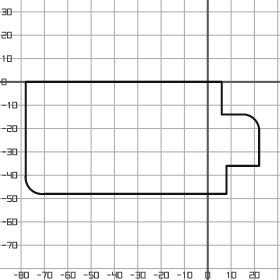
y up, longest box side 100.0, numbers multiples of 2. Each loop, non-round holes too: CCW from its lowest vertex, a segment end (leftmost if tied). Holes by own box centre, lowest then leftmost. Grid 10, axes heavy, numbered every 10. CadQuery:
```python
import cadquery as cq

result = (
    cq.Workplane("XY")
    .moveTo(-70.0, -48.0)
    .lineTo(8.0, -48.0)
    .lineTo(8.0, -36.0)
    .lineTo(22.0, -36.0)
    .lineTo(22.0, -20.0)
    .threePointArc((20.0, -16.0), (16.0, -14.0))
    .lineTo(6.0, -14.0)
    .lineTo(6.0, 0.0)
    .lineTo(-78.0, 0.0)
    .lineTo(-78.0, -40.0)
    .threePointArc((-76.0, -46.0), (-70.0, -48.0))
    .close()
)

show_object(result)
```